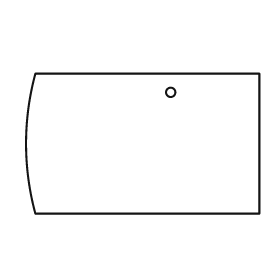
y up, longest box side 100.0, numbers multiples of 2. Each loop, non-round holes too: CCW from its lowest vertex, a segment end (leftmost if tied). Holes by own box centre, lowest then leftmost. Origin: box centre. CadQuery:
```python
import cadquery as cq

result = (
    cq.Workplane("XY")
    .moveTo(-46.0, -30.0)
    .lineTo(50.0, -30.0)
    .lineTo(50.0, 30.0)
    .lineTo(-46.0, 30.0)
    .threePointArc((-50.0, 0.0), (-46.0, -30.0))
    .close()
    .moveTo(12.0, 22.0)
    .circle(2.0)
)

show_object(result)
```